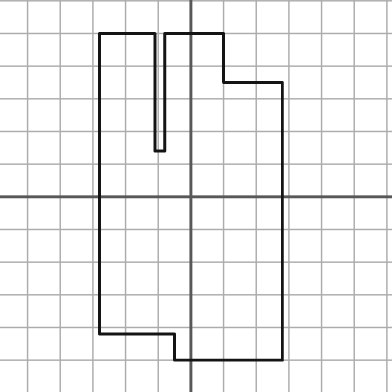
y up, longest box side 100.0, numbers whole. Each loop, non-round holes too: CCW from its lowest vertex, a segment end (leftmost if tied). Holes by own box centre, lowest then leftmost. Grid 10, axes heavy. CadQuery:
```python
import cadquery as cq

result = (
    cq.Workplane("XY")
    .moveTo(-5.0, -50.0)
    .lineTo(28.0, -50.0)
    .lineTo(28.0, 35.0)
    .lineTo(10.0, 35.0)
    .lineTo(10.0, 50.0)
    .lineTo(-8.0, 50.0)
    .lineTo(-8.0, 14.0)
    .lineTo(-11.0, 14.0)
    .lineTo(-11.0, 50.0)
    .lineTo(-28.0, 50.0)
    .lineTo(-28.0, -42.0)
    .lineTo(-5.0, -42.0)
    .close()
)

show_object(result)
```